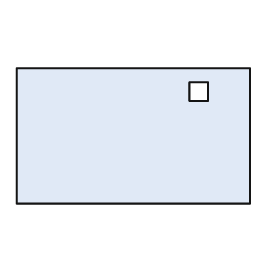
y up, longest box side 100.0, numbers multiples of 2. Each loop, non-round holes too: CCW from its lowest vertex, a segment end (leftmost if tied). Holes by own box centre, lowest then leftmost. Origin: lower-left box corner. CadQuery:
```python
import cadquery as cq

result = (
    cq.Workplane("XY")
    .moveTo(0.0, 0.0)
    .lineTo(100.0, 0.0)
    .lineTo(100.0, 58.0)
    .lineTo(0.0, 58.0)
    .close()
    .moveTo(74.0, 44.0)
    .lineTo(82.0, 44.0)
    .lineTo(82.0, 52.0)
    .lineTo(74.0, 52.0)
    .close()
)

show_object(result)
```